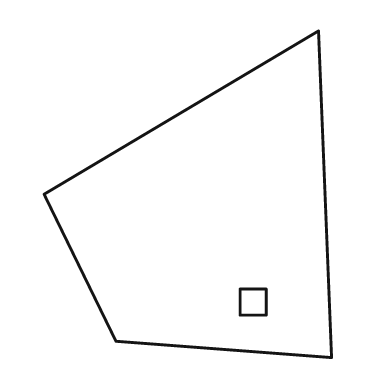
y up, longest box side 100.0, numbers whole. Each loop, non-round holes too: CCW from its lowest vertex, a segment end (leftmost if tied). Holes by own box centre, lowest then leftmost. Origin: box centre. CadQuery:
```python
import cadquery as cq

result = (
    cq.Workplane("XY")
    .moveTo(44.0, -50.0)
    .lineTo(40.0, 50.0)
    .lineTo(-44.0, 0.0)
    .lineTo(-22.0, -45.0)
    .close()
    .moveTo(16.0, -37.0)
    .lineTo(24.0, -37.0)
    .lineTo(24.0, -29.0)
    .lineTo(16.0, -29.0)
    .close()
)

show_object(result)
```